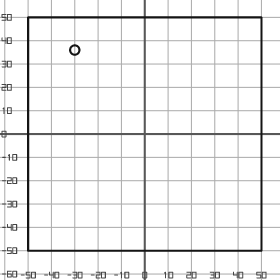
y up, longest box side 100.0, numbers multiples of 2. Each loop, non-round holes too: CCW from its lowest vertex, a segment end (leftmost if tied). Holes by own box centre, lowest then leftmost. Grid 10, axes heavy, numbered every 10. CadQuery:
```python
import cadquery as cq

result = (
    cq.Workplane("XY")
    .moveTo(-50.0, -50.0)
    .lineTo(50.0, -50.0)
    .lineTo(50.0, 50.0)
    .lineTo(-50.0, 50.0)
    .close()
    .moveTo(-30.0, 36.0)
    .circle(2.0)
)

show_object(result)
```